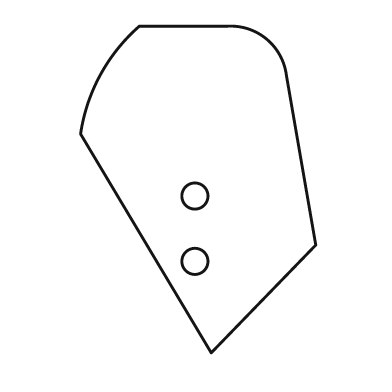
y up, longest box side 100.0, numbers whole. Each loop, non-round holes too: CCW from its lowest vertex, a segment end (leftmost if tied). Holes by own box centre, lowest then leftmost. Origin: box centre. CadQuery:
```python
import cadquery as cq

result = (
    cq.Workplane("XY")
    .moveTo(4.0, -50.0)
    .lineTo(36.0, -17.0)
    .lineTo(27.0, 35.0)
    .threePointArc((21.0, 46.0), (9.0, 50.0))
    .lineTo(-18.0, 50.0)
    .threePointArc((-30.0, 35.0), (-36.0, 17.0))
    .close()
    .moveTo(-1.0, -22.0)
    .circle(4.0)
    .moveTo(-1.0, -2.0)
    .circle(4.0)
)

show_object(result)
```